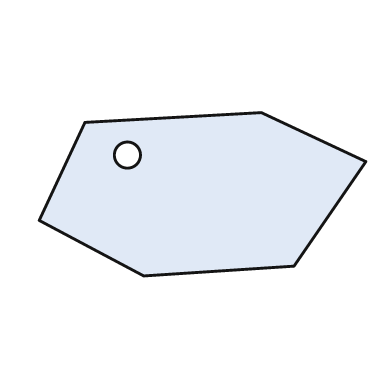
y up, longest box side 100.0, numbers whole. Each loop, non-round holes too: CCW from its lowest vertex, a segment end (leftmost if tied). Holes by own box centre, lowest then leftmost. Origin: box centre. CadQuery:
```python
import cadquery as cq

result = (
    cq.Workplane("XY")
    .moveTo(-18.0, -25.0)
    .lineTo(28.0, -22.0)
    .lineTo(50.0, 10.0)
    .lineTo(18.0, 25.0)
    .lineTo(-36.0, 22.0)
    .lineTo(-50.0, -8.0)
    .close()
    .moveTo(-23.0, 12.0)
    .circle(4.0)
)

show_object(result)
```